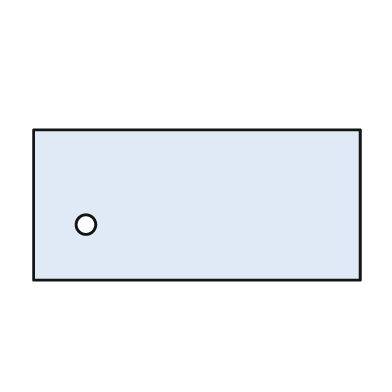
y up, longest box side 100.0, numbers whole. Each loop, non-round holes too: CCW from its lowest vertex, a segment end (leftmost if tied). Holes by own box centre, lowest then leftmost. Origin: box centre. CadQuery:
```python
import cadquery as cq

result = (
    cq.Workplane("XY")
    .moveTo(-50.0, -23.0)
    .lineTo(50.0, -23.0)
    .lineTo(50.0, 23.0)
    .lineTo(-50.0, 23.0)
    .close()
    .moveTo(-34.0, -6.0)
    .circle(3.0)
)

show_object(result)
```